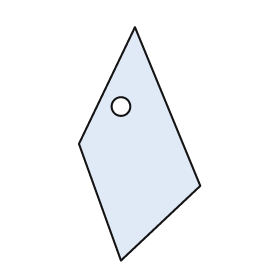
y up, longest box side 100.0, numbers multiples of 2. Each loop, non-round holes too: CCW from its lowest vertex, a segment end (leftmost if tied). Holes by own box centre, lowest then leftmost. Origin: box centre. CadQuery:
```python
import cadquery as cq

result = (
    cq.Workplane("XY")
    .moveTo(-8.0, -50.0)
    .lineTo(26.0, -18.0)
    .lineTo(-2.0, 50.0)
    .lineTo(-26.0, 0.0)
    .close()
    .moveTo(-8.0, 16.0)
    .circle(4.0)
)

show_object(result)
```